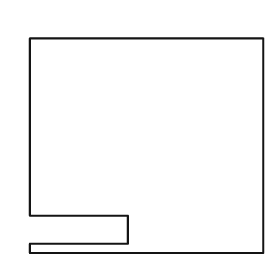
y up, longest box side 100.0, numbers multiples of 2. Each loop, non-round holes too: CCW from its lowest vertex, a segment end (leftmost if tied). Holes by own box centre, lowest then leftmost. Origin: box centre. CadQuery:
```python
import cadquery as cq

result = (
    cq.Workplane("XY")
    .moveTo(-50.0, -46.0)
    .lineTo(50.0, -46.0)
    .lineTo(50.0, 46.0)
    .lineTo(-50.0, 46.0)
    .lineTo(-50.0, -30.0)
    .lineTo(-8.0, -30.0)
    .lineTo(-8.0, -42.0)
    .lineTo(-50.0, -42.0)
    .close()
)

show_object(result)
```